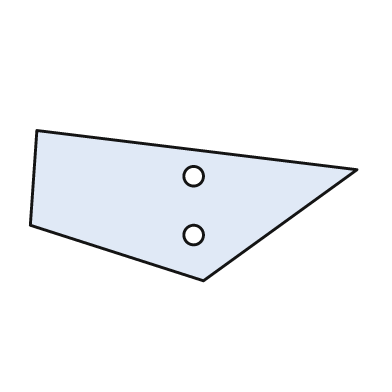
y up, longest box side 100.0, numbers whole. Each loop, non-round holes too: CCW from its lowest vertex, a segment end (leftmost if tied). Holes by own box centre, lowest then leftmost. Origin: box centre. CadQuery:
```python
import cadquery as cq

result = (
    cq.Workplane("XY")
    .moveTo(3.0, -23.0)
    .lineTo(50.0, 11.0)
    .lineTo(-48.0, 23.0)
    .lineTo(-50.0, -6.0)
    .close()
    .moveTo(0.0, -9.0)
    .circle(3.0)
    .moveTo(0.0, 9.0)
    .circle(3.0)
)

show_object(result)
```